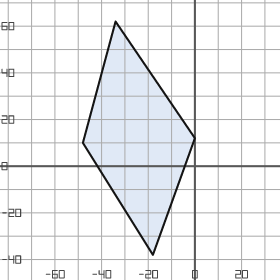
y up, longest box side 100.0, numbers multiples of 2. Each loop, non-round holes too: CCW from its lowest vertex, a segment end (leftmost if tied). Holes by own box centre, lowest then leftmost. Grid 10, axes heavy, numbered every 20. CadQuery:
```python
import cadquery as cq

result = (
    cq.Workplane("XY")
    .moveTo(-18.0, -38.0)
    .lineTo(0.0, 12.0)
    .lineTo(-34.0, 62.0)
    .lineTo(-48.0, 10.0)
    .close()
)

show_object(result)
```